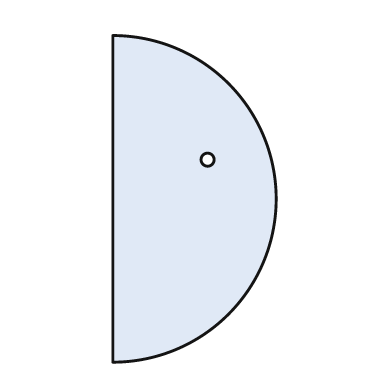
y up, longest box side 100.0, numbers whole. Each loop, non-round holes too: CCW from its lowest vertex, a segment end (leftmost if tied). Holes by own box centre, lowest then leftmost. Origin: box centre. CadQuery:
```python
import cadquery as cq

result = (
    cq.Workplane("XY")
    .moveTo(-25.0, -50.0)
    .threePointArc((25.0, 0.0), (-25.0, 50.0))
    .close()
    .moveTo(4.0, 12.0)
    .circle(2.0)
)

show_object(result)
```